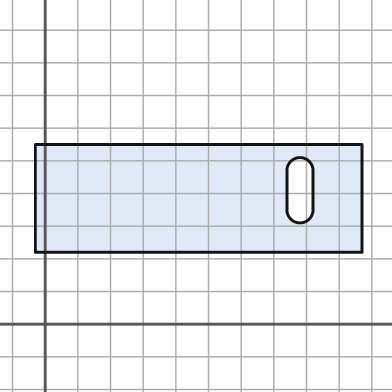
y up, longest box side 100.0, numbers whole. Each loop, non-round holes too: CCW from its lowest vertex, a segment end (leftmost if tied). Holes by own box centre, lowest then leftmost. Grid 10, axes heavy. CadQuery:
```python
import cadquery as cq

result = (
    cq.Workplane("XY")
    .moveTo(-3.0, 22.0)
    .lineTo(97.0, 22.0)
    .lineTo(97.0, 55.0)
    .lineTo(-3.0, 55.0)
    .close()
    .moveTo(74.0, 35.0)
    .threePointArc((78.0, 31.0), (82.0, 35.0))
    .lineTo(82.0, 47.0)
    .threePointArc((78.0, 51.0), (74.0, 47.0))
    .close()
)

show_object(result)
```